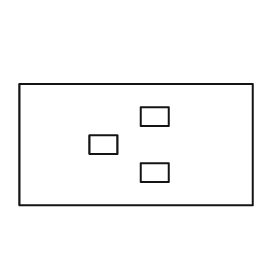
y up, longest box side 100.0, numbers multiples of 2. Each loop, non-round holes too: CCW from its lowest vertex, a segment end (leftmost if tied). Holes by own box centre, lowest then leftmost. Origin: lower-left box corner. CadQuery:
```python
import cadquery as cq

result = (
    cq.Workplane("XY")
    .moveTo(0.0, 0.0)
    .lineTo(100.0, 0.0)
    .lineTo(100.0, 52.0)
    .lineTo(0.0, 52.0)
    .close()
    .moveTo(52.0, 10.0)
    .lineTo(64.0, 10.0)
    .lineTo(64.0, 18.0)
    .lineTo(52.0, 18.0)
    .close()
    .moveTo(30.0, 22.0)
    .lineTo(42.0, 22.0)
    .lineTo(42.0, 30.0)
    .lineTo(30.0, 30.0)
    .close()
    .moveTo(52.0, 34.0)
    .lineTo(64.0, 34.0)
    .lineTo(64.0, 42.0)
    .lineTo(52.0, 42.0)
    .close()
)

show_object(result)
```